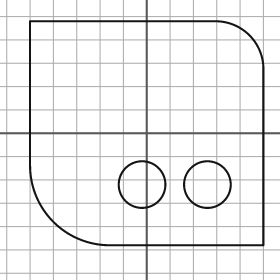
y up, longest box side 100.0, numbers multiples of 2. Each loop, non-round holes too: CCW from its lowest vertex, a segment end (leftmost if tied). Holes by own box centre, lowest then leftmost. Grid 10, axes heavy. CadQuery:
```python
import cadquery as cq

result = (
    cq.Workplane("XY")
    .moveTo(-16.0, -48.0)
    .lineTo(50.0, -48.0)
    .lineTo(50.0, 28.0)
    .threePointArc((44.0, 42.0), (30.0, 48.0))
    .lineTo(-50.0, 48.0)
    .lineTo(-50.0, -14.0)
    .threePointArc((-40.0, -38.0), (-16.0, -48.0))
    .close()
    .moveTo(-2.0, -22.0)
    .circle(10.0)
    .moveTo(26.0, -22.0)
    .circle(10.0)
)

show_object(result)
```